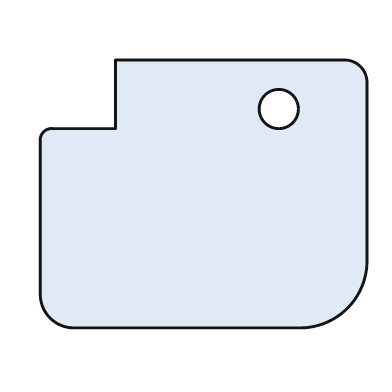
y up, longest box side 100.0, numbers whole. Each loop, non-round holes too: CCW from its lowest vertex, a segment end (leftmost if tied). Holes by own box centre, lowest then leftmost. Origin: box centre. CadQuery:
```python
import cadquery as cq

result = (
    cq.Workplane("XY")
    .moveTo(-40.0, -41.0)
    .lineTo(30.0, -41.0)
    .threePointArc((44.0, -35.0), (50.0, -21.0))
    .lineTo(50.0, 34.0)
    .threePointArc((48.0, 39.0), (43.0, 41.0))
    .lineTo(-27.0, 41.0)
    .lineTo(-27.0, 20.0)
    .lineTo(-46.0, 20.0)
    .threePointArc((-49.0, 19.0), (-50.0, 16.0))
    .lineTo(-50.0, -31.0)
    .threePointArc((-47.0, -38.0), (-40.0, -41.0))
    .close()
    .moveTo(23.0, 26.0)
    .circle(6.0)
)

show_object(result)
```